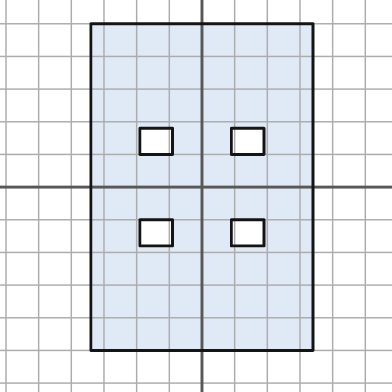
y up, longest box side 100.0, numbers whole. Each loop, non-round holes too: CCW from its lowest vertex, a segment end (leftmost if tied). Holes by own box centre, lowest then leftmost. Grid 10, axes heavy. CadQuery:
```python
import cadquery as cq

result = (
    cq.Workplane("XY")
    .moveTo(-34.0, -50.0)
    .lineTo(34.0, -50.0)
    .lineTo(34.0, 50.0)
    .lineTo(-34.0, 50.0)
    .close()
    .moveTo(-19.0, -18.0)
    .lineTo(-9.0, -18.0)
    .lineTo(-9.0, -10.0)
    .lineTo(-19.0, -10.0)
    .close()
    .moveTo(9.0, -18.0)
    .lineTo(19.0, -18.0)
    .lineTo(19.0, -10.0)
    .lineTo(9.0, -10.0)
    .close()
    .moveTo(-19.0, 10.0)
    .lineTo(-9.0, 10.0)
    .lineTo(-9.0, 18.0)
    .lineTo(-19.0, 18.0)
    .close()
    .moveTo(9.0, 10.0)
    .lineTo(19.0, 10.0)
    .lineTo(19.0, 18.0)
    .lineTo(9.0, 18.0)
    .close()
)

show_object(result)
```